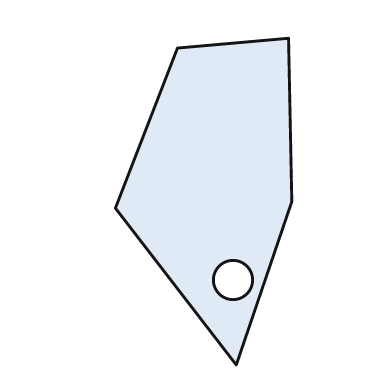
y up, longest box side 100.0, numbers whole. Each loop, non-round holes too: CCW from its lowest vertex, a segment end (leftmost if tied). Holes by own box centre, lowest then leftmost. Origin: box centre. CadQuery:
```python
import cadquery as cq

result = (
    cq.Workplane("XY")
    .moveTo(10.0, -50.0)
    .lineTo(27.0, 0.0)
    .lineTo(26.0, 50.0)
    .lineTo(-8.0, 47.0)
    .lineTo(-27.0, -2.0)
    .close()
    .moveTo(9.0, -24.0)
    .circle(6.0)
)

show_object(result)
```